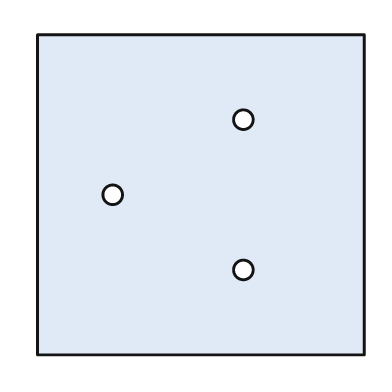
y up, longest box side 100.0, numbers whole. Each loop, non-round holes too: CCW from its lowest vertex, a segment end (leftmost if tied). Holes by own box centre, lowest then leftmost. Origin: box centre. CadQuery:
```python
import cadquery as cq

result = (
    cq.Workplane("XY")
    .moveTo(-50.0, -49.0)
    .lineTo(50.0, -49.0)
    .lineTo(50.0, 49.0)
    .lineTo(-50.0, 49.0)
    .close()
    .moveTo(13.0, -23.0)
    .circle(3.0)
    .moveTo(-27.0, 0.0)
    .circle(3.0)
    .moveTo(13.0, 23.0)
    .circle(3.0)
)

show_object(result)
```